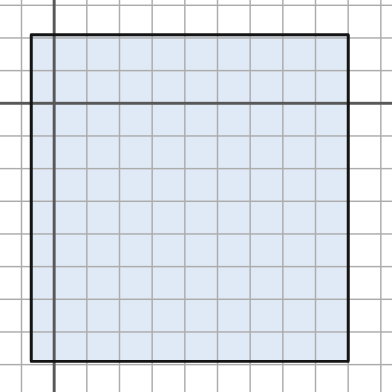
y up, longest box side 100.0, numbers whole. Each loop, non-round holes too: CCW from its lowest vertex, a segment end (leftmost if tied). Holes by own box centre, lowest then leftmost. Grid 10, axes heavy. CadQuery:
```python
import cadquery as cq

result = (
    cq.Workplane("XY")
    .moveTo(-7.0, -79.0)
    .lineTo(90.0, -79.0)
    .lineTo(90.0, 21.0)
    .lineTo(-7.0, 21.0)
    .close()
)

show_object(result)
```